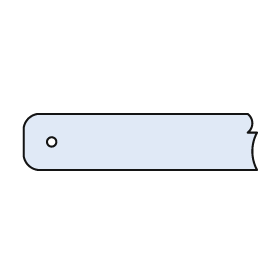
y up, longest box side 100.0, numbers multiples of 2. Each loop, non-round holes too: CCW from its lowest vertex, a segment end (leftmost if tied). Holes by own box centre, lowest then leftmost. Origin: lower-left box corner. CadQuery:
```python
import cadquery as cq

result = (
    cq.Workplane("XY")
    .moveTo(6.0, 0.0)
    .lineTo(100.0, 0.0)
    .threePointArc((98.0, 8.0), (100.0, 16.0))
    .lineTo(96.0, 16.0)
    .threePointArc((98.0, 20.0), (96.0, 24.0))
    .lineTo(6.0, 24.0)
    .threePointArc((2.0, 22.0), (0.0, 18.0))
    .lineTo(0.0, 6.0)
    .threePointArc((2.0, 2.0), (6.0, 0.0))
    .close()
    .moveTo(12.0, 12.0)
    .circle(2.0)
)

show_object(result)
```